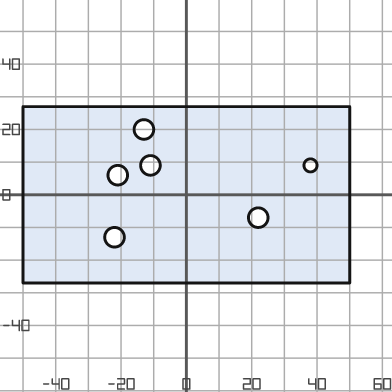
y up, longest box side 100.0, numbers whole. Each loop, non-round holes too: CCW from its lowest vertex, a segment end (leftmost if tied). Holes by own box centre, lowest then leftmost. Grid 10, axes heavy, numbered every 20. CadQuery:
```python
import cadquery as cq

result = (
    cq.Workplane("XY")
    .moveTo(-50.0, -27.0)
    .lineTo(50.0, -27.0)
    .lineTo(50.0, 27.0)
    .lineTo(-50.0, 27.0)
    .close()
    .moveTo(-22.0, -13.0)
    .circle(3.0)
    .moveTo(22.0, -7.0)
    .circle(3.0)
    .moveTo(-21.0, 6.0)
    .circle(3.0)
    .moveTo(-11.0, 9.0)
    .circle(3.0)
    .moveTo(38.0, 9.0)
    .circle(2.0)
    .moveTo(-13.0, 20.0)
    .circle(3.0)
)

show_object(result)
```